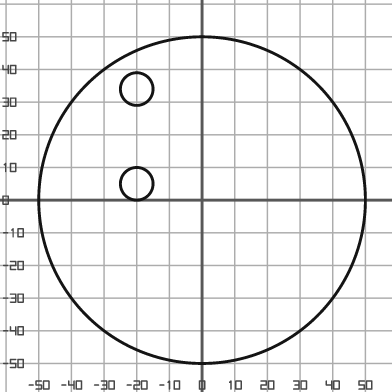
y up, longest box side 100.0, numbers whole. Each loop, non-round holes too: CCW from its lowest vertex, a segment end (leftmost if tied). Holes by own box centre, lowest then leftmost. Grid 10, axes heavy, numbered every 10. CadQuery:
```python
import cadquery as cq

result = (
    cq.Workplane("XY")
    .moveTo(0.0, 0.0)
    .circle(50.0)
    .moveTo(-20.0, 5.0)
    .circle(5.0)
    .moveTo(-20.0, 34.0)
    .circle(5.0)
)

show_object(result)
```